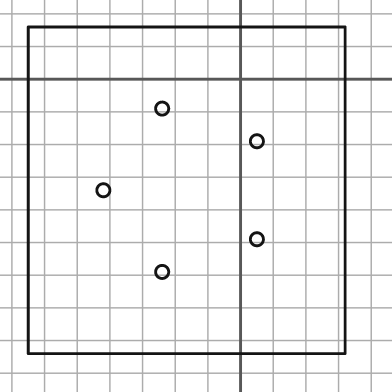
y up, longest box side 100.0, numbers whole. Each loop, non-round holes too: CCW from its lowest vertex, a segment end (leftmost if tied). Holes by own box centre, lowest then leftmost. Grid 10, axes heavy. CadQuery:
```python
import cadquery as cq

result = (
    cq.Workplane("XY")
    .moveTo(-65.0, -84.0)
    .lineTo(32.0, -84.0)
    .lineTo(32.0, 16.0)
    .lineTo(-65.0, 16.0)
    .close()
    .moveTo(-24.0, -59.0)
    .circle(2.0)
    .moveTo(5.0, -49.0)
    .circle(2.0)
    .moveTo(-42.0, -34.0)
    .circle(2.0)
    .moveTo(5.0, -19.0)
    .circle(2.0)
    .moveTo(-24.0, -9.0)
    .circle(2.0)
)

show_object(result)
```